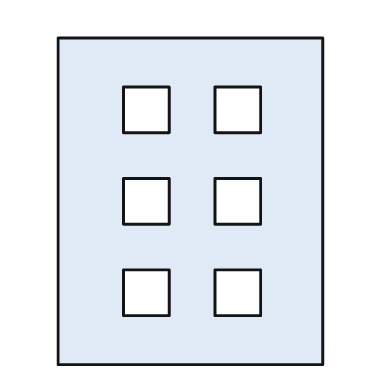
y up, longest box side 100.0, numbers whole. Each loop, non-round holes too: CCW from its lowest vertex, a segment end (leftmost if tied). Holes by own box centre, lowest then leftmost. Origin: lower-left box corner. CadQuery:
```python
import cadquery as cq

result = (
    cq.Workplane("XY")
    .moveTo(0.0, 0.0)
    .lineTo(81.0, 0.0)
    .lineTo(81.0, 100.0)
    .lineTo(0.0, 100.0)
    .close()
    .moveTo(20.0, 15.0)
    .lineTo(34.0, 15.0)
    .lineTo(34.0, 29.0)
    .lineTo(20.0, 29.0)
    .close()
    .moveTo(48.0, 15.0)
    .lineTo(62.0, 15.0)
    .lineTo(62.0, 29.0)
    .lineTo(48.0, 29.0)
    .close()
    .moveTo(20.0, 43.0)
    .lineTo(34.0, 43.0)
    .lineTo(34.0, 57.0)
    .lineTo(20.0, 57.0)
    .close()
    .moveTo(48.0, 43.0)
    .lineTo(62.0, 43.0)
    .lineTo(62.0, 57.0)
    .lineTo(48.0, 57.0)
    .close()
    .moveTo(20.0, 71.0)
    .lineTo(34.0, 71.0)
    .lineTo(34.0, 85.0)
    .lineTo(20.0, 85.0)
    .close()
    .moveTo(48.0, 71.0)
    .lineTo(62.0, 71.0)
    .lineTo(62.0, 85.0)
    .lineTo(48.0, 85.0)
    .close()
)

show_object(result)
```